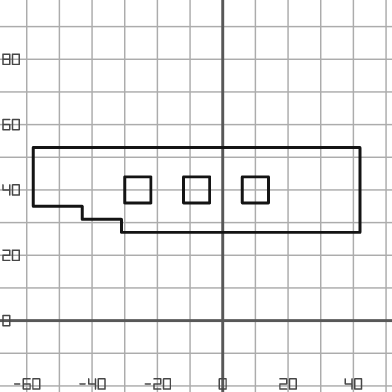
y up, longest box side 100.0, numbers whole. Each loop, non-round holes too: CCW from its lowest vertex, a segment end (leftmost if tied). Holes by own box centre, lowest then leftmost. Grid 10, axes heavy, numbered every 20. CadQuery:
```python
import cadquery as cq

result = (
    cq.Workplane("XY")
    .moveTo(-31.0, 27.0)
    .lineTo(42.0, 27.0)
    .lineTo(42.0, 53.0)
    .lineTo(-58.0, 53.0)
    .lineTo(-58.0, 35.0)
    .lineTo(-43.0, 35.0)
    .lineTo(-43.0, 31.0)
    .lineTo(-31.0, 31.0)
    .close()
    .moveTo(-30.0, 36.0)
    .lineTo(-22.0, 36.0)
    .lineTo(-22.0, 44.0)
    .lineTo(-30.0, 44.0)
    .close()
    .moveTo(-12.0, 36.0)
    .lineTo(-4.0, 36.0)
    .lineTo(-4.0, 44.0)
    .lineTo(-12.0, 44.0)
    .close()
    .moveTo(6.0, 36.0)
    .lineTo(14.0, 36.0)
    .lineTo(14.0, 44.0)
    .lineTo(6.0, 44.0)
    .close()
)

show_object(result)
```